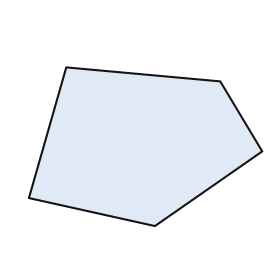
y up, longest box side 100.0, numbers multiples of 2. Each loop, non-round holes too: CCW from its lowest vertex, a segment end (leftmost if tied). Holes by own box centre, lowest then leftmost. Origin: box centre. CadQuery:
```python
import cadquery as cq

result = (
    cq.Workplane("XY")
    .moveTo(4.0, -34.0)
    .lineTo(50.0, -2.0)
    .lineTo(32.0, 28.0)
    .lineTo(-34.0, 34.0)
    .lineTo(-50.0, -22.0)
    .close()
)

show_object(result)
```